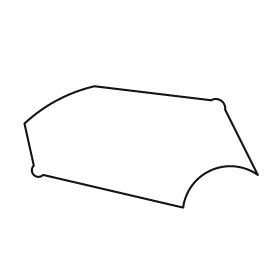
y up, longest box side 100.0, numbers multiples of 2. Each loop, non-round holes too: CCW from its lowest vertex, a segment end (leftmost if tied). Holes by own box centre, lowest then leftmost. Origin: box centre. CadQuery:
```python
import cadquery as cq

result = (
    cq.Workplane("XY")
    .moveTo(18.0, -26.0)
    .threePointArc((30.0, -10.0), (50.0, -12.0))
    .lineTo(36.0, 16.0)
    .threePointArc((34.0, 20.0), (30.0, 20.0))
    .lineTo(-20.0, 26.0)
    .threePointArc((-36.0, 20.0), (-50.0, 10.0))
    .lineTo(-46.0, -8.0)
    .threePointArc((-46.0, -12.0), (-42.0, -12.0))
    .close()
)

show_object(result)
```